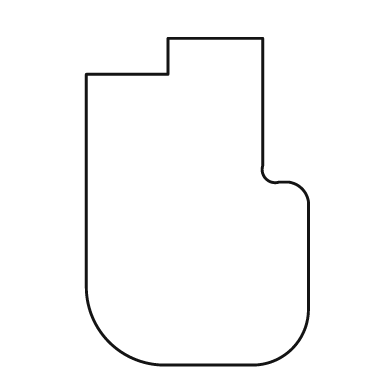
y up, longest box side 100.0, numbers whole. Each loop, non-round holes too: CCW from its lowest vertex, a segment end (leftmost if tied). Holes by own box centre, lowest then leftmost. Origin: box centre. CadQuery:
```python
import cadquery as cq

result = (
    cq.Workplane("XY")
    .moveTo(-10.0, -50.0)
    .lineTo(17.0, -50.0)
    .threePointArc((29.0, -45.0), (34.0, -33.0))
    .lineTo(34.0, 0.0)
    .threePointArc((32.0, 4.0), (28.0, 6.0))
    .lineTo(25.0, 6.0)
    .threePointArc((21.0, 7.0), (20.0, 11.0))
    .lineTo(20.0, 50.0)
    .lineTo(-9.0, 50.0)
    .lineTo(-9.0, 39.0)
    .lineTo(-34.0, 39.0)
    .lineTo(-34.0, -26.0)
    .threePointArc((-27.0, -43.0), (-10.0, -50.0))
    .close()
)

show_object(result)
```